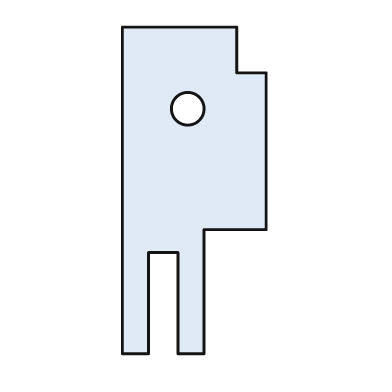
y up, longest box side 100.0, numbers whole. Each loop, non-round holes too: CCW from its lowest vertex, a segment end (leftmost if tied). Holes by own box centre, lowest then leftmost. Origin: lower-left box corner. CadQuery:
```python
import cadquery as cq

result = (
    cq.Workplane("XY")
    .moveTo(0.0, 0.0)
    .lineTo(8.0, 0.0)
    .lineTo(8.0, 31.0)
    .lineTo(17.0, 31.0)
    .lineTo(17.0, 0.0)
    .lineTo(25.0, 0.0)
    .lineTo(25.0, 38.0)
    .lineTo(44.0, 38.0)
    .lineTo(44.0, 86.0)
    .lineTo(35.0, 86.0)
    .lineTo(35.0, 100.0)
    .lineTo(0.0, 100.0)
    .close()
    .moveTo(20.0, 75.0)
    .circle(5.0)
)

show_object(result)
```